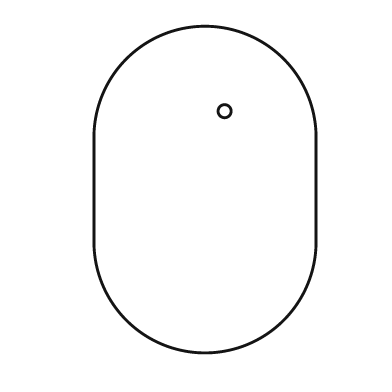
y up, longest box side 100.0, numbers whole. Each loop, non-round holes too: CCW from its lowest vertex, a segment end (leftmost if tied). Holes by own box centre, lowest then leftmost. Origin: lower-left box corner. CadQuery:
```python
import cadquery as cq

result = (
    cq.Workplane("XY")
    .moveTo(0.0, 34.0)
    .threePointArc((34.0, 0.0), (68.0, 34.0))
    .lineTo(68.0, 66.0)
    .threePointArc((34.0, 100.0), (0.0, 66.0))
    .close()
    .moveTo(40.0, 74.0)
    .circle(2.0)
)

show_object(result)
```